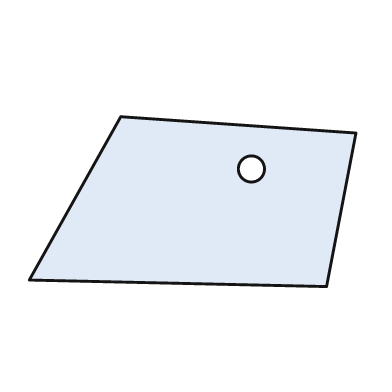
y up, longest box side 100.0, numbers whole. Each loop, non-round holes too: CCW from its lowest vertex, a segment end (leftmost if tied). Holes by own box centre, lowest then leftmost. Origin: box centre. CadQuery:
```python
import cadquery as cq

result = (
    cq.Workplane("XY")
    .moveTo(41.0, -26.0)
    .lineTo(50.0, 21.0)
    .lineTo(-22.0, 26.0)
    .lineTo(-50.0, -24.0)
    .close()
    .moveTo(18.0, 10.0)
    .circle(4.0)
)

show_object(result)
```